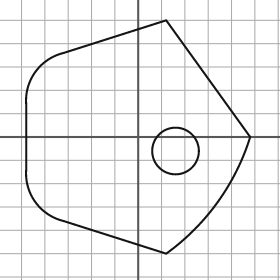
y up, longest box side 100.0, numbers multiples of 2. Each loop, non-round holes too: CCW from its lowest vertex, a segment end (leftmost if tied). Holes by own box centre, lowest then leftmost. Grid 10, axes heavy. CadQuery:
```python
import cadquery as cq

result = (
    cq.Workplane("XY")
    .moveTo(12.0, -50.0)
    .threePointArc((34.0, -28.0), (48.0, 0.0))
    .lineTo(12.0, 50.0)
    .lineTo(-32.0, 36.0)
    .threePointArc((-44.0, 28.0), (-48.0, 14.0))
    .lineTo(-48.0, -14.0)
    .threePointArc((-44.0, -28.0), (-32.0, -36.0))
    .close()
    .moveTo(16.0, -6.0)
    .circle(10.0)
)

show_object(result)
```